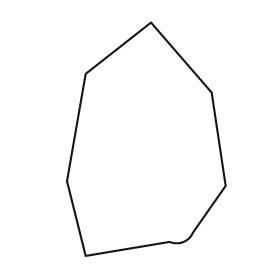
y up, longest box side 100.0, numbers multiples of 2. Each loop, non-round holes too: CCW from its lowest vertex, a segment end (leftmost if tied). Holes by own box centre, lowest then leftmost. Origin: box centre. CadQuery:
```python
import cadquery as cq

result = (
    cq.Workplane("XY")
    .moveTo(-26.0, -50.0)
    .lineTo(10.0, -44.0)
    .threePointArc((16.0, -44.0), (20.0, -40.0))
    .lineTo(34.0, -20.0)
    .lineTo(28.0, 20.0)
    .lineTo(2.0, 50.0)
    .lineTo(-26.0, 28.0)
    .lineTo(-34.0, -18.0)
    .close()
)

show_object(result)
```